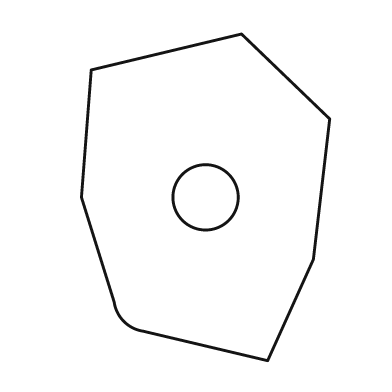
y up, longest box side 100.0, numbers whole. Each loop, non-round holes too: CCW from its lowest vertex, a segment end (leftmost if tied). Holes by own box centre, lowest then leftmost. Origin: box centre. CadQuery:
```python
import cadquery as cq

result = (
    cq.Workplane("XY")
    .moveTo(19.0, -50.0)
    .lineTo(33.0, -19.0)
    .lineTo(38.0, 24.0)
    .lineTo(11.0, 50.0)
    .lineTo(-35.0, 39.0)
    .lineTo(-38.0, 0.0)
    .lineTo(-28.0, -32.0)
    .threePointArc((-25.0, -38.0), (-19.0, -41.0))
    .close()
    .moveTo(0.0, 0.0)
    .circle(10.0)
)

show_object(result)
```